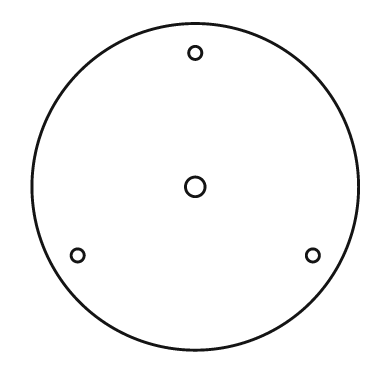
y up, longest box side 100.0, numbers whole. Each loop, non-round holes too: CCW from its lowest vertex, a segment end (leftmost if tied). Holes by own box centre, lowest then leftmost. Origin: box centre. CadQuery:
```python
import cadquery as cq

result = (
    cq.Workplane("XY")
    .moveTo(0.0, 0.0)
    .circle(50.0)
    .moveTo(-36.0, -21.0)
    .circle(2.0)
    .moveTo(36.0, -21.0)
    .circle(2.0)
    .moveTo(0.0, 0.0)
    .circle(3.0)
    .moveTo(0.0, 41.0)
    .circle(2.0)
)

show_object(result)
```